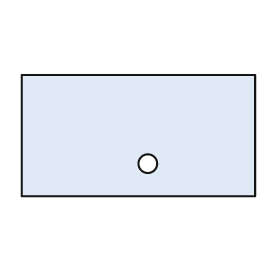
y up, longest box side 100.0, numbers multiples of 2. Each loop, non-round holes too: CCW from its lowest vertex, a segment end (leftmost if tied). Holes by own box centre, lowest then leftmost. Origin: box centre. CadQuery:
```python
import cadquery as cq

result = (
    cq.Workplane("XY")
    .moveTo(-50.0, -26.0)
    .lineTo(50.0, -26.0)
    .lineTo(50.0, 26.0)
    .lineTo(-50.0, 26.0)
    .close()
    .moveTo(4.0, -12.0)
    .circle(4.0)
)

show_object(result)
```